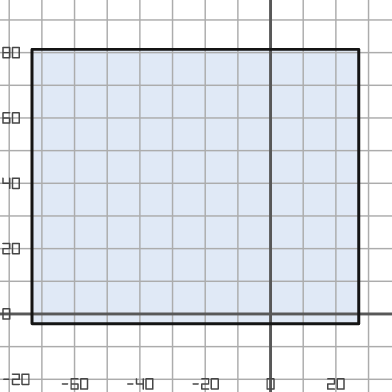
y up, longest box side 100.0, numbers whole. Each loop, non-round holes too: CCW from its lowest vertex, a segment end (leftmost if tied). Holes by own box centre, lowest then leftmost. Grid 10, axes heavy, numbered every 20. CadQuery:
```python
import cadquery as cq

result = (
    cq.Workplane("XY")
    .moveTo(-73.0, -3.0)
    .lineTo(27.0, -3.0)
    .lineTo(27.0, 81.0)
    .lineTo(-73.0, 81.0)
    .close()
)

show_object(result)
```